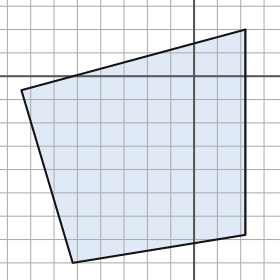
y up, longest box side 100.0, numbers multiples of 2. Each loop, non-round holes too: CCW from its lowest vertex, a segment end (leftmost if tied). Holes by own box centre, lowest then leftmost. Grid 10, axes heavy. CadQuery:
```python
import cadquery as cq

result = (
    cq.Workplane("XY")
    .moveTo(-52.0, -80.0)
    .lineTo(22.0, -68.0)
    .lineTo(22.0, 20.0)
    .lineTo(-74.0, -6.0)
    .close()
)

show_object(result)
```